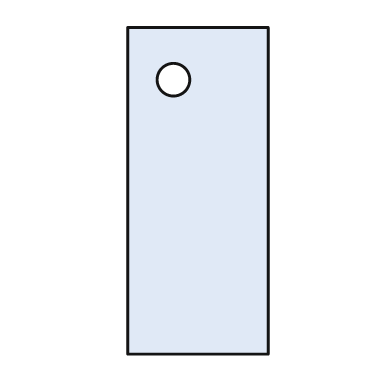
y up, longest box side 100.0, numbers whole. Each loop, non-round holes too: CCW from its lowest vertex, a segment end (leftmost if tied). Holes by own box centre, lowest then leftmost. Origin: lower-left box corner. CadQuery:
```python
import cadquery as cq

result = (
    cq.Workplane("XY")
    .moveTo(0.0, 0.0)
    .lineTo(43.0, 0.0)
    .lineTo(43.0, 100.0)
    .lineTo(0.0, 100.0)
    .close()
    .moveTo(14.0, 84.0)
    .circle(5.0)
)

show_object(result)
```